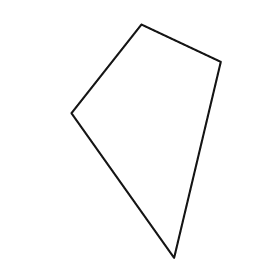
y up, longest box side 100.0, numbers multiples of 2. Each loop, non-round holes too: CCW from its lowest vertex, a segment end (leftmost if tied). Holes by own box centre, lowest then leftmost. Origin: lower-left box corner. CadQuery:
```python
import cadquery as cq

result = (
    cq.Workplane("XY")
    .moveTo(44.0, 0.0)
    .lineTo(64.0, 84.0)
    .lineTo(30.0, 100.0)
    .lineTo(0.0, 62.0)
    .close()
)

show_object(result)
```